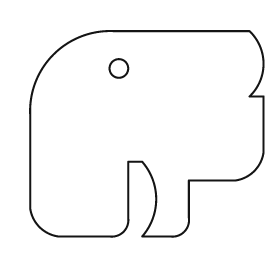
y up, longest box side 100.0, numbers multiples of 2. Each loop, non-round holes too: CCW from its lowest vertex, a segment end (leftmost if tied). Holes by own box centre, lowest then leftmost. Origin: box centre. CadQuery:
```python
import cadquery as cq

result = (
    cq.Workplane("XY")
    .moveTo(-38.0, -44.0)
    .lineTo(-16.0, -44.0)
    .threePointArc((-10.0, -42.0), (-8.0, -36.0))
    .lineTo(-8.0, -12.0)
    .lineTo(-2.0, -12.0)
    .threePointArc((4.0, -28.0), (-2.0, -44.0))
    .lineTo(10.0, -44.0)
    .threePointArc((16.0, -42.0), (18.0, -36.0))
    .lineTo(18.0, -20.0)
    .lineTo(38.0, -20.0)
    .threePointArc((46.0, -16.0), (50.0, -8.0))
    .lineTo(50.0, 16.0)
    .lineTo(44.0, 16.0)
    .threePointArc((50.0, 30.0), (44.0, 44.0))
    .lineTo(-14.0, 44.0)
    .threePointArc((-40.0, 34.0), (-50.0, 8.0))
    .lineTo(-50.0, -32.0)
    .threePointArc((-46.0, -40.0), (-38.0, -44.0))
    .close()
    .moveTo(-12.0, 28.0)
    .circle(4.0)
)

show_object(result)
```